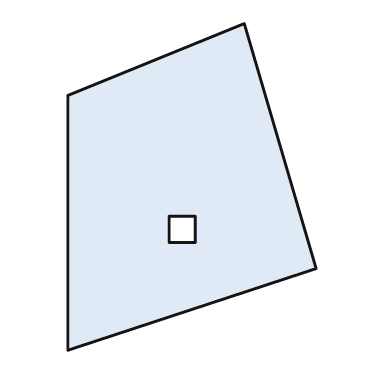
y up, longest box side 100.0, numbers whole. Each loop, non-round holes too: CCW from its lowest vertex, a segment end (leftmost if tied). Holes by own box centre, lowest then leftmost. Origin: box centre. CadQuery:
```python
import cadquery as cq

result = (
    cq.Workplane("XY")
    .moveTo(-38.0, -50.0)
    .lineTo(38.0, -25.0)
    .lineTo(16.0, 50.0)
    .lineTo(-38.0, 28.0)
    .close()
    .moveTo(-7.0, -17.0)
    .lineTo(1.0, -17.0)
    .lineTo(1.0, -9.0)
    .lineTo(-7.0, -9.0)
    .close()
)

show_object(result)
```